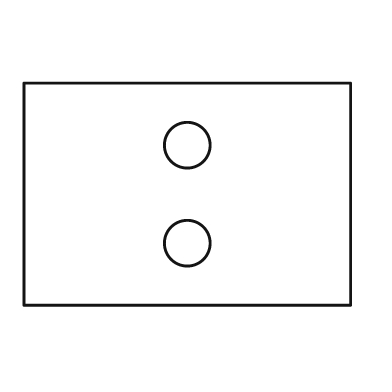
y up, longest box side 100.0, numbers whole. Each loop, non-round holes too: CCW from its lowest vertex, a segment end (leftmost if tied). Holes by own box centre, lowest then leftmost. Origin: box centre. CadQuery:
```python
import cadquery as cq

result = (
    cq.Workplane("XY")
    .moveTo(-50.0, -34.0)
    .lineTo(50.0, -34.0)
    .lineTo(50.0, 34.0)
    .lineTo(-50.0, 34.0)
    .close()
    .moveTo(0.0, -15.0)
    .circle(7.0)
    .moveTo(0.0, 15.0)
    .circle(7.0)
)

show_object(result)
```